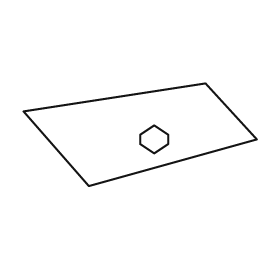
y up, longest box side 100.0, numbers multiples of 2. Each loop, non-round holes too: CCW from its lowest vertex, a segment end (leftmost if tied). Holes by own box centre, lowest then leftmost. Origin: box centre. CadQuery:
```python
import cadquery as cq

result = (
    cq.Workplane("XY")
    .moveTo(-22.0, -22.0)
    .lineTo(50.0, -2.0)
    .lineTo(28.0, 22.0)
    .lineTo(-50.0, 10.0)
    .close()
    .moveTo(6.0, -8.0)
    .lineTo(12.0, -4.0)
    .lineTo(12.0, 0.0)
    .lineTo(6.0, 4.0)
    .lineTo(0.0, 0.0)
    .lineTo(0.0, -4.0)
    .close()
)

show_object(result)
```